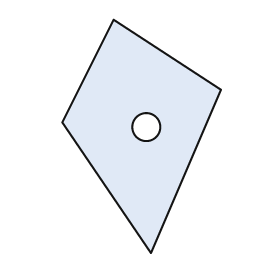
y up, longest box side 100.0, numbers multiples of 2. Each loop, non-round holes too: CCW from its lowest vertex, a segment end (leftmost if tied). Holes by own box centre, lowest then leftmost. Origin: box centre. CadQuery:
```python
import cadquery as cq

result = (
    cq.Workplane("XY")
    .moveTo(4.0, -50.0)
    .lineTo(34.0, 20.0)
    .lineTo(-12.0, 50.0)
    .lineTo(-34.0, 6.0)
    .close()
    .moveTo(2.0, 4.0)
    .circle(6.0)
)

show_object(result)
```